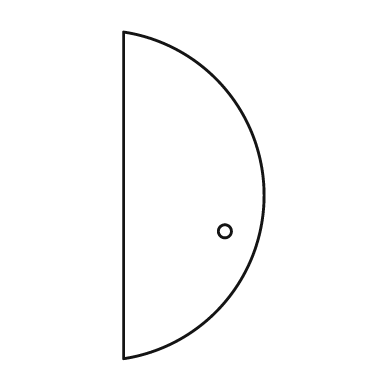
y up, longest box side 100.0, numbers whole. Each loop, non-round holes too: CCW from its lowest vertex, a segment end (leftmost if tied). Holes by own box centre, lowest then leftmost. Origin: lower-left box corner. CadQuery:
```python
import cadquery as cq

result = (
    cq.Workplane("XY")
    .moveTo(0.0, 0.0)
    .threePointArc((43.0, 50.0), (0.0, 100.0))
    .close()
    .moveTo(31.0, 39.0)
    .circle(2.0)
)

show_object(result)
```